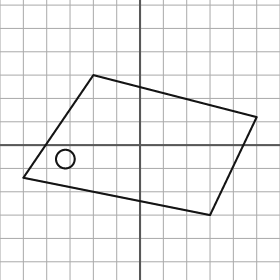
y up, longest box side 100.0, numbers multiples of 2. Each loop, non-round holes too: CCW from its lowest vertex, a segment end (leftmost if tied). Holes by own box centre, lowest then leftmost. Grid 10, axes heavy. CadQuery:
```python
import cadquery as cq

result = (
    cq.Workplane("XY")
    .moveTo(30.0, -30.0)
    .lineTo(50.0, 12.0)
    .lineTo(-20.0, 30.0)
    .lineTo(-50.0, -14.0)
    .close()
    .moveTo(-32.0, -6.0)
    .circle(4.0)
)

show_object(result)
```